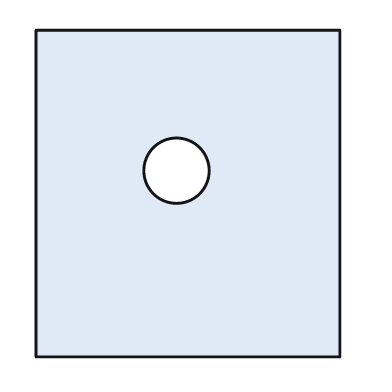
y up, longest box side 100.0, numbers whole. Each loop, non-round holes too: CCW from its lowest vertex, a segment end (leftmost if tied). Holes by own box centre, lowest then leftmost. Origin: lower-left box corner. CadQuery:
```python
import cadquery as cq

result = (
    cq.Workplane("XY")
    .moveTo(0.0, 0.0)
    .lineTo(93.0, 0.0)
    .lineTo(93.0, 100.0)
    .lineTo(0.0, 100.0)
    .close()
    .moveTo(43.0, 57.0)
    .circle(10.0)
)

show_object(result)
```